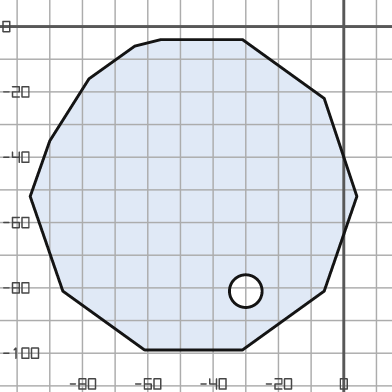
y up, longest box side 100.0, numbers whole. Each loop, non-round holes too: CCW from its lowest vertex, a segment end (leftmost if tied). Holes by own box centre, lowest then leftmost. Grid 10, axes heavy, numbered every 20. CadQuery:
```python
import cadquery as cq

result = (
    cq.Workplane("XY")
    .moveTo(-61.0, -99.0)
    .lineTo(-31.0, -99.0)
    .lineTo(-6.0, -81.0)
    .lineTo(4.0, -52.0)
    .lineTo(-6.0, -22.0)
    .lineTo(-31.0, -4.0)
    .lineTo(-56.0, -4.0)
    .lineTo(-64.0, -6.0)
    .lineTo(-78.0, -16.0)
    .lineTo(-90.0, -35.0)
    .lineTo(-96.0, -52.0)
    .lineTo(-86.0, -81.0)
    .close()
    .moveTo(-30.0, -81.0)
    .circle(5.0)
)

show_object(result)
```